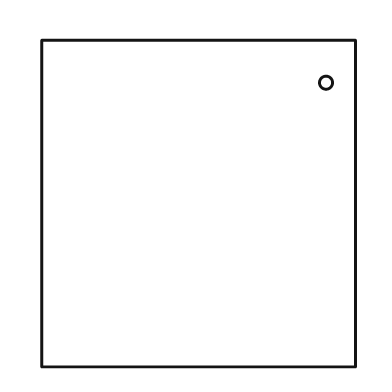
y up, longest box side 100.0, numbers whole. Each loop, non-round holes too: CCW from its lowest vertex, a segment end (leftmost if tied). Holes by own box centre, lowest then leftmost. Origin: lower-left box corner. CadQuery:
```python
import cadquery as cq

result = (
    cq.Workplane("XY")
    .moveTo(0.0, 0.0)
    .lineTo(96.0, 0.0)
    .lineTo(96.0, 100.0)
    .lineTo(0.0, 100.0)
    .close()
    .moveTo(87.0, 87.0)
    .circle(2.0)
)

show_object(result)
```